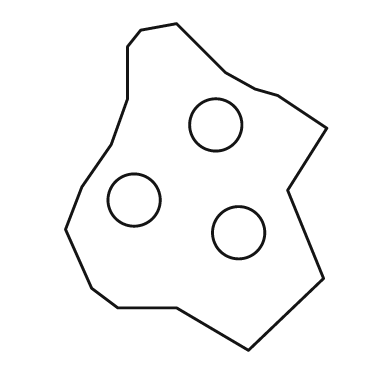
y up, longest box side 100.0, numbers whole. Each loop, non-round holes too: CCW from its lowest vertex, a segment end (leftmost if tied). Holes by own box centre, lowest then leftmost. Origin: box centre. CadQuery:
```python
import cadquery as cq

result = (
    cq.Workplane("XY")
    .moveTo(16.0, -50.0)
    .lineTo(39.0, -28.0)
    .lineTo(28.0, -1.0)
    .lineTo(40.0, 18.0)
    .lineTo(25.0, 28.0)
    .lineTo(18.0, 30.0)
    .lineTo(9.0, 35.0)
    .lineTo(-6.0, 50.0)
    .lineTo(-17.0, 48.0)
    .lineTo(-21.0, 43.0)
    .lineTo(-21.0, 27.0)
    .lineTo(-26.0, 13.0)
    .lineTo(-35.0, 0.0)
    .lineTo(-40.0, -13.0)
    .lineTo(-32.0, -31.0)
    .lineTo(-24.0, -37.0)
    .lineTo(-6.0, -37.0)
    .close()
    .moveTo(13.0, -14.0)
    .circle(8.0)
    .moveTo(-19.0, -4.0)
    .circle(8.0)
    .moveTo(6.0, 19.0)
    .circle(8.0)
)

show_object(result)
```